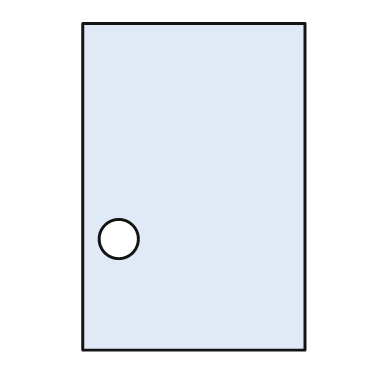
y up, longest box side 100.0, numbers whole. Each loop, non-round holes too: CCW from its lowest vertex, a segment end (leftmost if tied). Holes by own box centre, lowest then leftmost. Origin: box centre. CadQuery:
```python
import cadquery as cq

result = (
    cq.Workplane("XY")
    .moveTo(-34.0, -50.0)
    .lineTo(34.0, -50.0)
    .lineTo(34.0, 50.0)
    .lineTo(-34.0, 50.0)
    .close()
    .moveTo(-23.0, -16.0)
    .circle(6.0)
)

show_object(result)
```